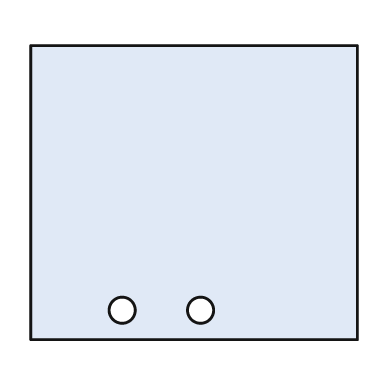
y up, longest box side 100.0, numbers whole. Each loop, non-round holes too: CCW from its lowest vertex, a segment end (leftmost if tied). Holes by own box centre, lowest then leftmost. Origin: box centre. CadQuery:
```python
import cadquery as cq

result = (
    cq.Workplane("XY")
    .moveTo(-50.0, -45.0)
    .lineTo(50.0, -45.0)
    .lineTo(50.0, 45.0)
    .lineTo(-50.0, 45.0)
    .close()
    .moveTo(-22.0, -36.0)
    .circle(4.0)
    .moveTo(2.0, -36.0)
    .circle(4.0)
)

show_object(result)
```